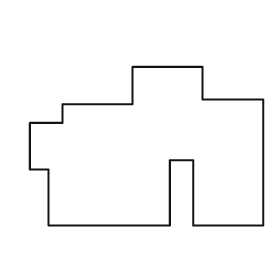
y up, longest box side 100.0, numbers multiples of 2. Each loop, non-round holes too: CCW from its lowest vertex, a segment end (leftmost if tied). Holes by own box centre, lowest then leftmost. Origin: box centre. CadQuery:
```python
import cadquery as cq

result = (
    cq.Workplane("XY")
    .moveTo(-42.0, -34.0)
    .lineTo(10.0, -34.0)
    .lineTo(10.0, -6.0)
    .lineTo(20.0, -6.0)
    .lineTo(20.0, -34.0)
    .lineTo(50.0, -34.0)
    .lineTo(50.0, 20.0)
    .lineTo(24.0, 20.0)
    .lineTo(24.0, 34.0)
    .lineTo(-6.0, 34.0)
    .lineTo(-6.0, 18.0)
    .lineTo(-36.0, 18.0)
    .lineTo(-36.0, 10.0)
    .lineTo(-50.0, 10.0)
    .lineTo(-50.0, -10.0)
    .lineTo(-42.0, -10.0)
    .close()
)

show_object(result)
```